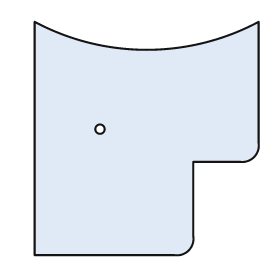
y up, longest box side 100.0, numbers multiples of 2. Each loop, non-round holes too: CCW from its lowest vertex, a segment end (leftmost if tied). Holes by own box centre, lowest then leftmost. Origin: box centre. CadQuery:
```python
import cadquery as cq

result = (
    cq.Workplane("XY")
    .moveTo(-48.0, -50.0)
    .lineTo(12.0, -50.0)
    .threePointArc((18.0, -48.0), (20.0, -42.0))
    .lineTo(20.0, -10.0)
    .lineTo(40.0, -10.0)
    .threePointArc((46.0, -8.0), (48.0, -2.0))
    .lineTo(48.0, 50.0)
    .threePointArc((0.0, 38.0), (-48.0, 50.0))
    .close()
    .moveTo(-20.0, 4.0)
    .circle(2.0)
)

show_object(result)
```